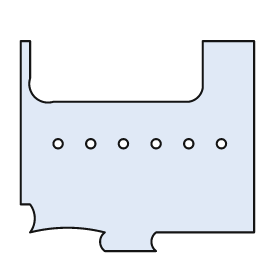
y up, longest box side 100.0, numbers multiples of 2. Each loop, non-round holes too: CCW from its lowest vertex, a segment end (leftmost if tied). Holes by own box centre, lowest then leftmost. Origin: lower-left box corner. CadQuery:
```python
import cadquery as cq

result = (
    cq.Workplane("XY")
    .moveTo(36.0, 0.0)
    .lineTo(58.0, 0.0)
    .threePointArc((56.0, 4.0), (58.0, 8.0))
    .lineTo(100.0, 8.0)
    .lineTo(100.0, 90.0)
    .lineTo(78.0, 90.0)
    .lineTo(78.0, 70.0)
    .threePointArc((76.0, 66.0), (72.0, 64.0))
    .lineTo(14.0, 64.0)
    .threePointArc((6.0, 66.0), (4.0, 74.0))
    .lineTo(4.0, 90.0)
    .lineTo(0.0, 90.0)
    .lineTo(0.0, 20.0)
    .lineTo(4.0, 20.0)
    .threePointArc((6.0, 14.0), (4.0, 8.0))
    .threePointArc((20.0, 10.0), (36.0, 8.0))
    .threePointArc((34.0, 4.0), (36.0, 0.0))
    .close()
    .moveTo(16.0, 46.0)
    .circle(2.0)
    .moveTo(30.0, 46.0)
    .circle(2.0)
    .moveTo(44.0, 46.0)
    .circle(2.0)
    .moveTo(58.0, 46.0)
    .circle(2.0)
    .moveTo(72.0, 46.0)
    .circle(2.0)
    .moveTo(86.0, 46.0)
    .circle(2.0)
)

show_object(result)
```